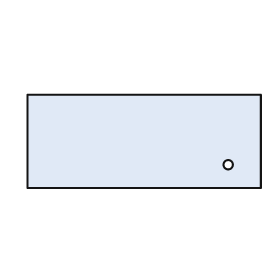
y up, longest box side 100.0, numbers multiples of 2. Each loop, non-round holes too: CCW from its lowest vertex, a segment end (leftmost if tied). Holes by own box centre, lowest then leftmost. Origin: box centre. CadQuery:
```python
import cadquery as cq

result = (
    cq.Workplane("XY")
    .moveTo(-50.0, -20.0)
    .lineTo(50.0, -20.0)
    .lineTo(50.0, 20.0)
    .lineTo(-50.0, 20.0)
    .close()
    .moveTo(36.0, -10.0)
    .circle(2.0)
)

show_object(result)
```